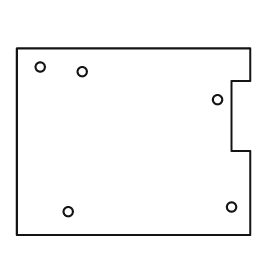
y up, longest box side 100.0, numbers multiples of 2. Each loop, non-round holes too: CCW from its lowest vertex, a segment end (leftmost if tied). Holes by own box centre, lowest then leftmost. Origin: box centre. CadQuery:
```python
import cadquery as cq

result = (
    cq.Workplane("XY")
    .moveTo(-50.0, -40.0)
    .lineTo(50.0, -40.0)
    .lineTo(50.0, -4.0)
    .lineTo(42.0, -4.0)
    .lineTo(42.0, 26.0)
    .lineTo(50.0, 26.0)
    .lineTo(50.0, 40.0)
    .lineTo(-50.0, 40.0)
    .close()
    .moveTo(-28.0, -30.0)
    .circle(2.0)
    .moveTo(42.0, -28.0)
    .circle(2.0)
    .moveTo(36.0, 18.0)
    .circle(2.0)
    .moveTo(-22.0, 30.0)
    .circle(2.0)
    .moveTo(-40.0, 32.0)
    .circle(2.0)
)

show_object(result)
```